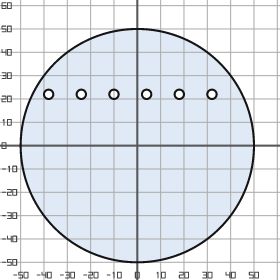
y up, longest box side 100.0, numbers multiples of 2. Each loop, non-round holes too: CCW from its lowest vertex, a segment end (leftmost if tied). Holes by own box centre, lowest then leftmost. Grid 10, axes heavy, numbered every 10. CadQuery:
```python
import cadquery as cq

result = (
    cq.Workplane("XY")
    .moveTo(0.0, 0.0)
    .circle(50.0)
    .moveTo(-38.0, 22.0)
    .circle(2.0)
    .moveTo(-24.0, 22.0)
    .circle(2.0)
    .moveTo(-10.0, 22.0)
    .circle(2.0)
    .moveTo(4.0, 22.0)
    .circle(2.0)
    .moveTo(18.0, 22.0)
    .circle(2.0)
    .moveTo(32.0, 22.0)
    .circle(2.0)
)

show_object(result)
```